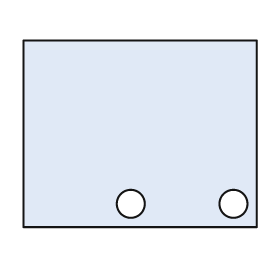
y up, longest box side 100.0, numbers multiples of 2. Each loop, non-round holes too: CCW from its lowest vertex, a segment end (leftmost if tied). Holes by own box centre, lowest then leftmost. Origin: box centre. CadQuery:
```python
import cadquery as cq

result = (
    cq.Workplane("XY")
    .moveTo(-50.0, -40.0)
    .lineTo(50.0, -40.0)
    .lineTo(50.0, 40.0)
    .lineTo(-50.0, 40.0)
    .close()
    .moveTo(-4.0, -30.0)
    .circle(6.0)
    .moveTo(40.0, -30.0)
    .circle(6.0)
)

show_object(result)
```